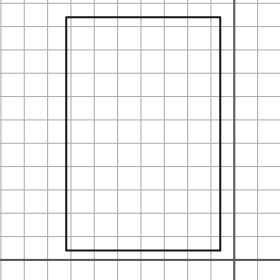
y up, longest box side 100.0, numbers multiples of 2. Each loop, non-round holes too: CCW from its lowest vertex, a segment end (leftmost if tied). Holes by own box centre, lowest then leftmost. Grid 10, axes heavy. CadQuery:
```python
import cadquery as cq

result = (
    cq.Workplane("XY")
    .moveTo(-72.0, 4.0)
    .lineTo(-6.0, 4.0)
    .lineTo(-6.0, 104.0)
    .lineTo(-72.0, 104.0)
    .close()
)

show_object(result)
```